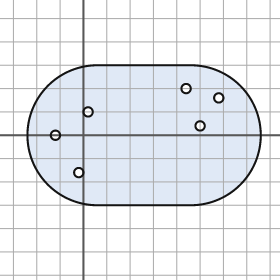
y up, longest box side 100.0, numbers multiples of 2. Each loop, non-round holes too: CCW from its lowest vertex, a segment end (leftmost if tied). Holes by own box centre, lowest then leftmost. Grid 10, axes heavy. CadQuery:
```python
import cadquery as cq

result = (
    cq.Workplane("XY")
    .moveTo(6.0, -30.0)
    .lineTo(46.0, -30.0)
    .threePointArc((76.0, 0.0), (46.0, 30.0))
    .lineTo(6.0, 30.0)
    .threePointArc((-24.0, 0.0), (6.0, -30.0))
    .close()
    .moveTo(-2.0, -16.0)
    .circle(2.0)
    .moveTo(-12.0, 0.0)
    .circle(2.0)
    .moveTo(50.0, 4.0)
    .circle(2.0)
    .moveTo(2.0, 10.0)
    .circle(2.0)
    .moveTo(58.0, 16.0)
    .circle(2.0)
    .moveTo(44.0, 20.0)
    .circle(2.0)
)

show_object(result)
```